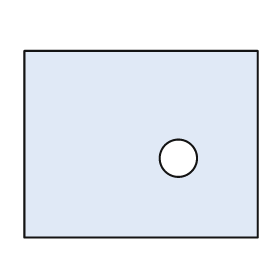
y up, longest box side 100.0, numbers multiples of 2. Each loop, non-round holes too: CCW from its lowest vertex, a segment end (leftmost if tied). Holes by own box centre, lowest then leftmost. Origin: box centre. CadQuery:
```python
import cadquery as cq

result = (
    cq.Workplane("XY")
    .moveTo(-50.0, -40.0)
    .lineTo(50.0, -40.0)
    .lineTo(50.0, 40.0)
    .lineTo(-50.0, 40.0)
    .close()
    .moveTo(16.0, -6.0)
    .circle(8.0)
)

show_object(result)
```